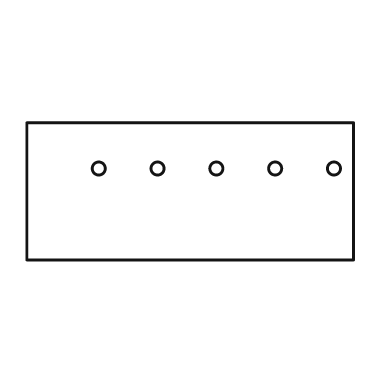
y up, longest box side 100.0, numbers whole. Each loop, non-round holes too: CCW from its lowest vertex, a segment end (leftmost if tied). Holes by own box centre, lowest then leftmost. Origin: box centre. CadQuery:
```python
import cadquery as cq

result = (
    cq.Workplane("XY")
    .moveTo(-50.0, -21.0)
    .lineTo(50.0, -21.0)
    .lineTo(50.0, 21.0)
    .lineTo(-50.0, 21.0)
    .close()
    .moveTo(-28.0, 7.0)
    .circle(2.0)
    .moveTo(-10.0, 7.0)
    .circle(2.0)
    .moveTo(8.0, 7.0)
    .circle(2.0)
    .moveTo(26.0, 7.0)
    .circle(2.0)
    .moveTo(44.0, 7.0)
    .circle(2.0)
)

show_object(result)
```